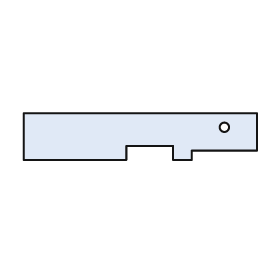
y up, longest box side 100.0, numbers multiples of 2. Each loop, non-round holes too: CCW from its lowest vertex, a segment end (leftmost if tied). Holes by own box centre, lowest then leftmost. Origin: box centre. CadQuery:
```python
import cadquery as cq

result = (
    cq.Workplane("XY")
    .moveTo(-50.0, -10.0)
    .lineTo(-6.0, -10.0)
    .lineTo(-6.0, -4.0)
    .lineTo(14.0, -4.0)
    .lineTo(14.0, -10.0)
    .lineTo(22.0, -10.0)
    .lineTo(22.0, -6.0)
    .lineTo(50.0, -6.0)
    .lineTo(50.0, 10.0)
    .lineTo(-50.0, 10.0)
    .close()
    .moveTo(36.0, 4.0)
    .circle(2.0)
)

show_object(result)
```